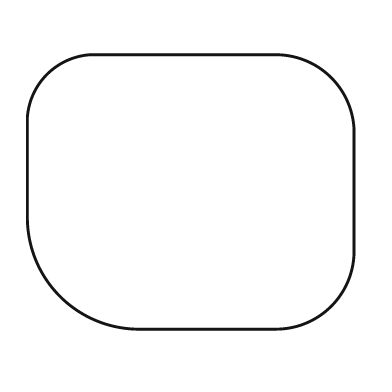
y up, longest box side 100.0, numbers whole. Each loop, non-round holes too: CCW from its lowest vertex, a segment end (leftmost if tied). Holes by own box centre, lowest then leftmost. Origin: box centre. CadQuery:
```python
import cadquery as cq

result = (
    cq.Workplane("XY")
    .moveTo(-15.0, -42.0)
    .lineTo(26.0, -42.0)
    .threePointArc((43.0, -35.0), (50.0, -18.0))
    .lineTo(50.0, 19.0)
    .threePointArc((43.0, 35.0), (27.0, 42.0))
    .lineTo(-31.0, 42.0)
    .threePointArc((-44.0, 36.0), (-50.0, 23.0))
    .lineTo(-50.0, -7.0)
    .threePointArc((-40.0, -32.0), (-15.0, -42.0))
    .close()
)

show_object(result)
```